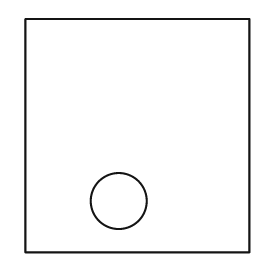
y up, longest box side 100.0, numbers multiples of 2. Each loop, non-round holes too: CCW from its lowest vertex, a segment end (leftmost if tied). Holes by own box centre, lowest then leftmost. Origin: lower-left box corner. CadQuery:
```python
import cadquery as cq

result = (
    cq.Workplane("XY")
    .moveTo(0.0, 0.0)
    .lineTo(96.0, 0.0)
    .lineTo(96.0, 100.0)
    .lineTo(0.0, 100.0)
    .close()
    .moveTo(40.0, 22.0)
    .circle(12.0)
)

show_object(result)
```